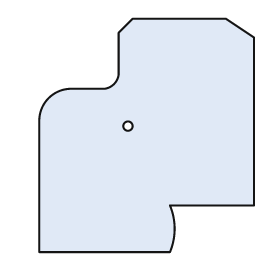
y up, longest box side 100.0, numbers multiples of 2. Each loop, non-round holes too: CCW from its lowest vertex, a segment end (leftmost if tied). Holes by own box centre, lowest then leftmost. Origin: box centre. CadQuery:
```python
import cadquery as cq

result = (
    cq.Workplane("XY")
    .moveTo(-46.0, -50.0)
    .lineTo(10.0, -50.0)
    .threePointArc((12.0, -40.0), (10.0, -30.0))
    .lineTo(46.0, -30.0)
    .lineTo(46.0, 42.0)
    .lineTo(34.0, 50.0)
    .lineTo(-6.0, 50.0)
    .lineTo(-12.0, 44.0)
    .lineTo(-12.0, 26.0)
    .threePointArc((-14.0, 22.0), (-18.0, 20.0))
    .lineTo(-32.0, 20.0)
    .threePointArc((-42.0, 16.0), (-46.0, 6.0))
    .close()
    .moveTo(-8.0, 4.0)
    .circle(2.0)
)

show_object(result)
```